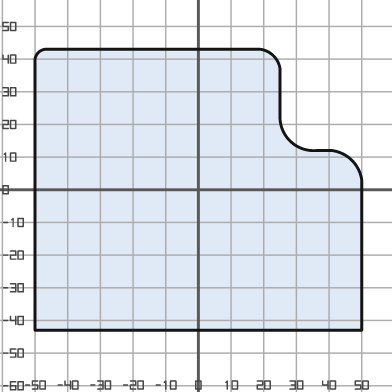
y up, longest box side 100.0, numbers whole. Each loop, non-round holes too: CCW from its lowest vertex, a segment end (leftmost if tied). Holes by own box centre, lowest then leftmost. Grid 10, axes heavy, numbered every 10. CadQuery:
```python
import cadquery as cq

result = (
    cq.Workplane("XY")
    .moveTo(-50.0, -43.0)
    .lineTo(50.0, -43.0)
    .lineTo(50.0, 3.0)
    .threePointArc((47.0, 9.0), (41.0, 12.0))
    .lineTo(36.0, 12.0)
    .threePointArc((28.0, 15.0), (25.0, 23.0))
    .lineTo(25.0, 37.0)
    .threePointArc((23.0, 41.0), (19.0, 43.0))
    .lineTo(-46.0, 43.0)
    .threePointArc((-49.0, 42.0), (-50.0, 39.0))
    .close()
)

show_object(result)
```